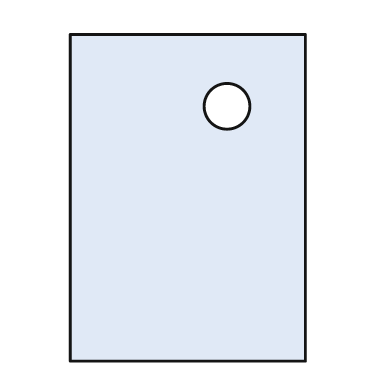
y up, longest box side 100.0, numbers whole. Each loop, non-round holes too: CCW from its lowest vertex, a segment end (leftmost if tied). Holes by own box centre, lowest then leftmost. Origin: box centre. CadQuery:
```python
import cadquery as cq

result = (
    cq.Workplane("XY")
    .moveTo(-36.0, -50.0)
    .lineTo(36.0, -50.0)
    .lineTo(36.0, 50.0)
    .lineTo(-36.0, 50.0)
    .close()
    .moveTo(12.0, 28.0)
    .circle(7.0)
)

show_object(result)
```